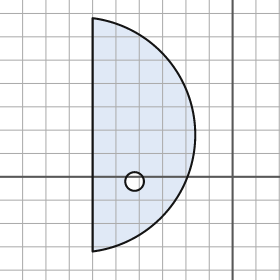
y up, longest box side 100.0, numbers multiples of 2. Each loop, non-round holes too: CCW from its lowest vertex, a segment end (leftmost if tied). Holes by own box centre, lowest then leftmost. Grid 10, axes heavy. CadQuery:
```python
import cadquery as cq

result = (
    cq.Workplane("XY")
    .moveTo(-60.0, -32.0)
    .threePointArc((-16.0, 18.0), (-60.0, 68.0))
    .close()
    .moveTo(-42.0, -2.0)
    .circle(4.0)
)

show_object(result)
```